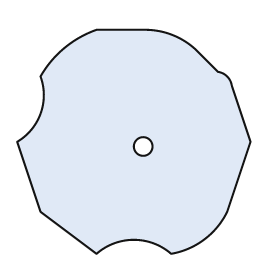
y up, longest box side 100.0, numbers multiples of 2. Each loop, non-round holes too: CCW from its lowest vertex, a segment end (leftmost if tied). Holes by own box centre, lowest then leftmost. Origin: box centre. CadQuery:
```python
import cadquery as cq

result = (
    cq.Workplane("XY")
    .moveTo(-16.0, -48.0)
    .threePointArc((0.0, -42.0), (16.0, -48.0))
    .threePointArc((30.0, -42.0), (40.0, -30.0))
    .lineTo(50.0, 0.0)
    .lineTo(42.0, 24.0)
    .threePointArc((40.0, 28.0), (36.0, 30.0))
    .lineTo(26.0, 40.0)
    .threePointArc((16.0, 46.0), (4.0, 48.0))
    .lineTo(-16.0, 48.0)
    .threePointArc((-30.0, 40.0), (-40.0, 28.0))
    .threePointArc((-40.0, 12.0), (-50.0, 0.0))
    .lineTo(-40.0, -30.0)
    .close()
    .moveTo(4.0, -2.0)
    .circle(4.0)
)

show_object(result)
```